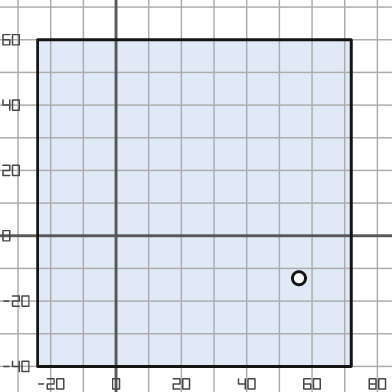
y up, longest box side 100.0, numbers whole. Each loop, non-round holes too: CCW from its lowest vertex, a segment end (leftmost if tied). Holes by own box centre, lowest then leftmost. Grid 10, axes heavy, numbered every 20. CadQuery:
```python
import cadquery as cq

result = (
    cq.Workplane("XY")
    .moveTo(-24.0, -40.0)
    .lineTo(72.0, -40.0)
    .lineTo(72.0, 60.0)
    .lineTo(-24.0, 60.0)
    .close()
    .moveTo(56.0, -13.0)
    .circle(2.0)
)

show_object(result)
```